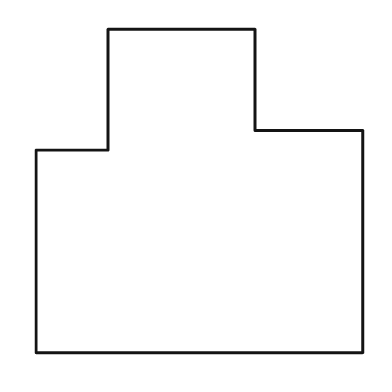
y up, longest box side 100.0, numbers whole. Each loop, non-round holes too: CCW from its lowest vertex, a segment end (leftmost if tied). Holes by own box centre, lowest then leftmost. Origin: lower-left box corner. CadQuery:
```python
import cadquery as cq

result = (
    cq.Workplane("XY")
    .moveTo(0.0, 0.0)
    .lineTo(100.0, 0.0)
    .lineTo(100.0, 68.0)
    .lineTo(67.0, 68.0)
    .lineTo(67.0, 99.0)
    .lineTo(22.0, 99.0)
    .lineTo(22.0, 62.0)
    .lineTo(0.0, 62.0)
    .close()
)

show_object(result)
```